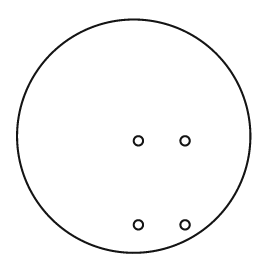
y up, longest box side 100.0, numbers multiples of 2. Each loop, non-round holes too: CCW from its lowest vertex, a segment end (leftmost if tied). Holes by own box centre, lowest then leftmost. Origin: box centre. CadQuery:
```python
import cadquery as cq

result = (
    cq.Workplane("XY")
    .moveTo(0.0, 0.0)
    .circle(50.0)
    .moveTo(2.0, -38.0)
    .circle(2.0)
    .moveTo(22.0, -38.0)
    .circle(2.0)
    .moveTo(2.0, -2.0)
    .circle(2.0)
    .moveTo(22.0, -2.0)
    .circle(2.0)
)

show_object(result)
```